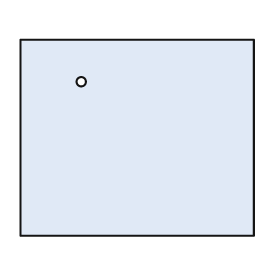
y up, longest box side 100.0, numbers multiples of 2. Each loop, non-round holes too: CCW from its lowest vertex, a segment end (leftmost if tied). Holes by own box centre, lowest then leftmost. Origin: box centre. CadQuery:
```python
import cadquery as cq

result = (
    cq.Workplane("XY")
    .moveTo(-50.0, -42.0)
    .lineTo(50.0, -42.0)
    .lineTo(50.0, 42.0)
    .lineTo(-50.0, 42.0)
    .close()
    .moveTo(-24.0, 24.0)
    .circle(2.0)
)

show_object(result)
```